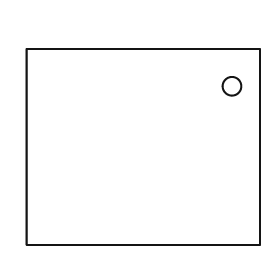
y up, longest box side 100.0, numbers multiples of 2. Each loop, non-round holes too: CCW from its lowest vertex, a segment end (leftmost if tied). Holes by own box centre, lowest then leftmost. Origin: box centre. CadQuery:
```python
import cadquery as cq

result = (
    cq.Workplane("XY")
    .moveTo(-50.0, -42.0)
    .lineTo(50.0, -42.0)
    .lineTo(50.0, 42.0)
    .lineTo(-50.0, 42.0)
    .close()
    .moveTo(38.0, 26.0)
    .circle(4.0)
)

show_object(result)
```